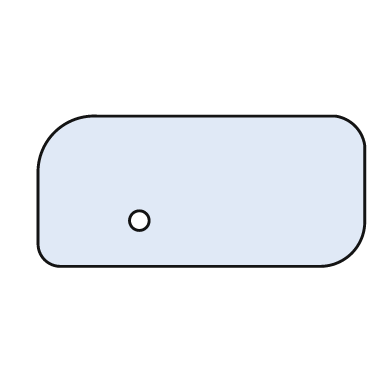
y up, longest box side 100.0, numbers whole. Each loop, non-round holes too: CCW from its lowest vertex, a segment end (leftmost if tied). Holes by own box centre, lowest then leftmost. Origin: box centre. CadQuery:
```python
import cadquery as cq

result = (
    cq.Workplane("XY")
    .moveTo(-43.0, -23.0)
    .lineTo(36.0, -23.0)
    .threePointArc((46.0, -19.0), (50.0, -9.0))
    .lineTo(50.0, 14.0)
    .threePointArc((47.0, 20.0), (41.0, 23.0))
    .lineTo(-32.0, 23.0)
    .threePointArc((-45.0, 18.0), (-50.0, 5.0))
    .lineTo(-50.0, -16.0)
    .threePointArc((-48.0, -21.0), (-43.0, -23.0))
    .close()
    .moveTo(-19.0, -9.0)
    .circle(3.0)
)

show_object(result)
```